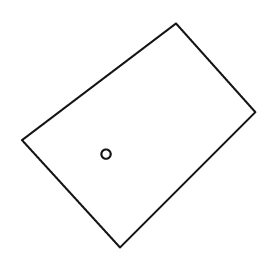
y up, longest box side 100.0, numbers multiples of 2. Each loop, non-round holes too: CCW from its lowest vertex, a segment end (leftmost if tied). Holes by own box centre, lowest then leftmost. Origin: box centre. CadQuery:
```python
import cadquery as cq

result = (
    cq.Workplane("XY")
    .moveTo(-8.0, -48.0)
    .lineTo(50.0, 10.0)
    .lineTo(16.0, 48.0)
    .lineTo(-50.0, -2.0)
    .close()
    .moveTo(-14.0, -8.0)
    .circle(2.0)
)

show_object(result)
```